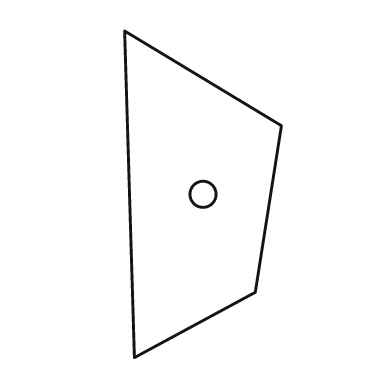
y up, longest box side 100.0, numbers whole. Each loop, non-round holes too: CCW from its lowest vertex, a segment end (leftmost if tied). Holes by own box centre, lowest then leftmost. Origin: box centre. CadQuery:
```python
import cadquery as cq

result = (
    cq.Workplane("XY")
    .moveTo(-21.0, -50.0)
    .lineTo(16.0, -30.0)
    .lineTo(24.0, 21.0)
    .lineTo(-24.0, 50.0)
    .close()
    .moveTo(0.0, 0.0)
    .circle(4.0)
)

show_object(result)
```